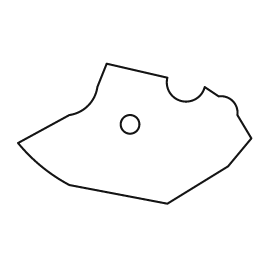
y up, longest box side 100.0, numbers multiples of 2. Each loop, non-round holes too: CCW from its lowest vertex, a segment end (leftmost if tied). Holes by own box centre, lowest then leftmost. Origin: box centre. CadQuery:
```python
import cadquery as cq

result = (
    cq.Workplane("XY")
    .moveTo(14.0, -30.0)
    .lineTo(40.0, -14.0)
    .lineTo(50.0, -2.0)
    .lineTo(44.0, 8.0)
    .threePointArc((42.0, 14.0), (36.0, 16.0))
    .lineTo(30.0, 20.0)
    .threePointArc((20.0, 14.0), (14.0, 24.0))
    .lineTo(-12.0, 30.0)
    .lineTo(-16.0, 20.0)
    .threePointArc((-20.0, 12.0), (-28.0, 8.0))
    .lineTo(-50.0, -4.0)
    .threePointArc((-40.0, -14.0), (-28.0, -22.0))
    .close()
    .moveTo(-2.0, 4.0)
    .circle(4.0)
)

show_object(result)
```